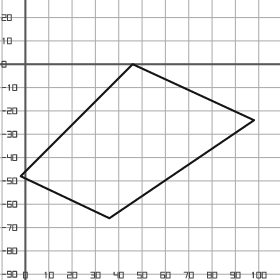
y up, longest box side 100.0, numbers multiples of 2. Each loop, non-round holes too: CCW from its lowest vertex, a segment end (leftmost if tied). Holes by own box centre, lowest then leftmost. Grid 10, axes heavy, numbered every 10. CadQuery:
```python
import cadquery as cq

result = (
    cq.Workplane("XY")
    .moveTo(36.0, -66.0)
    .lineTo(98.0, -24.0)
    .lineTo(46.0, 0.0)
    .lineTo(-2.0, -48.0)
    .close()
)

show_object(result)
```